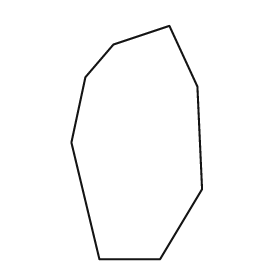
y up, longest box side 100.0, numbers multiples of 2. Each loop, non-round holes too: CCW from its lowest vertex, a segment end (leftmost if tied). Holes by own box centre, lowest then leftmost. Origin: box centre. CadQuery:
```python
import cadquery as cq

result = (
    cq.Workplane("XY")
    .moveTo(-16.0, -50.0)
    .lineTo(10.0, -50.0)
    .lineTo(28.0, -20.0)
    .lineTo(26.0, 24.0)
    .lineTo(14.0, 50.0)
    .lineTo(-10.0, 42.0)
    .lineTo(-22.0, 28.0)
    .lineTo(-28.0, 0.0)
    .close()
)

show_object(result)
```